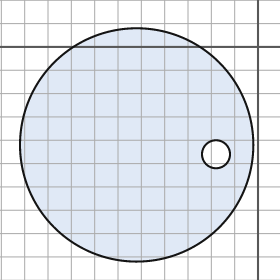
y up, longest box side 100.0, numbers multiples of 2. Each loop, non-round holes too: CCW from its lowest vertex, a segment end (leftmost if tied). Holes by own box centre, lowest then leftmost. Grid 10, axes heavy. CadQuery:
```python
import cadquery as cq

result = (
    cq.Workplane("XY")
    .moveTo(-52.0, -42.0)
    .circle(50.0)
    .moveTo(-18.0, -46.0)
    .circle(6.0)
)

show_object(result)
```